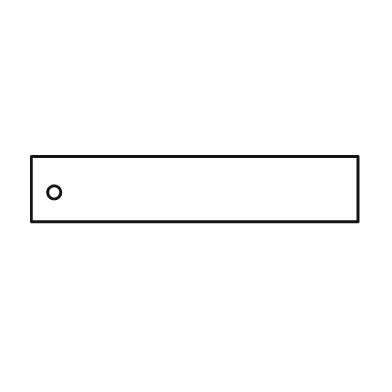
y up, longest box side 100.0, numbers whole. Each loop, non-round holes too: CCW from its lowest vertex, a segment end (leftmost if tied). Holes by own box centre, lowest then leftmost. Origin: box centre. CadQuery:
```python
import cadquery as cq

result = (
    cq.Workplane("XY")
    .moveTo(-50.0, -10.0)
    .lineTo(50.0, -10.0)
    .lineTo(50.0, 10.0)
    .lineTo(-50.0, 10.0)
    .close()
    .moveTo(-43.0, -1.0)
    .circle(2.0)
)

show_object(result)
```